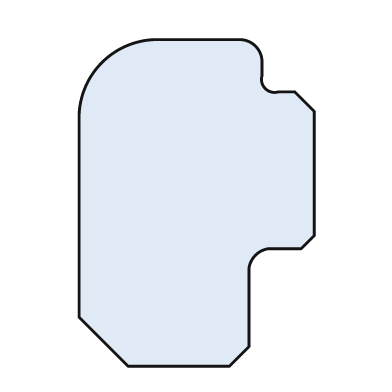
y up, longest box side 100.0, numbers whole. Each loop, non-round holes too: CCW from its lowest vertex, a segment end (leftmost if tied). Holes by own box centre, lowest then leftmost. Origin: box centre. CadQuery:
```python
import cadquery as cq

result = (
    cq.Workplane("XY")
    .moveTo(-21.0, -50.0)
    .lineTo(10.0, -50.0)
    .lineTo(16.0, -44.0)
    .lineTo(16.0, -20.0)
    .threePointArc((18.0, -16.0), (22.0, -14.0))
    .lineTo(32.0, -14.0)
    .lineTo(36.0, -10.0)
    .lineTo(36.0, 28.0)
    .lineTo(30.0, 34.0)
    .lineTo(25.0, 34.0)
    .threePointArc((21.0, 35.0), (20.0, 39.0))
    .lineTo(20.0, 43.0)
    .threePointArc((18.0, 48.0), (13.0, 50.0))
    .lineTo(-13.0, 50.0)
    .threePointArc((-29.0, 43.0), (-36.0, 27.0))
    .lineTo(-36.0, -35.0)
    .close()
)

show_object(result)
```